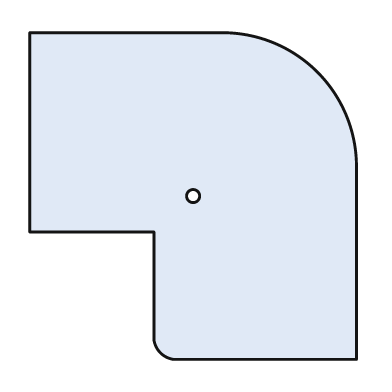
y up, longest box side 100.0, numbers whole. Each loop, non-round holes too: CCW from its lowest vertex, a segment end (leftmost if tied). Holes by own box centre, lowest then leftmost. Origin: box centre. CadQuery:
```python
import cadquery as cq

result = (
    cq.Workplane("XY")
    .moveTo(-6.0, -50.0)
    .lineTo(50.0, -50.0)
    .lineTo(50.0, 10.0)
    .threePointArc((38.0, 38.0), (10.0, 50.0))
    .lineTo(-50.0, 50.0)
    .lineTo(-50.0, -11.0)
    .lineTo(-12.0, -11.0)
    .lineTo(-12.0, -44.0)
    .threePointArc((-10.0, -48.0), (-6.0, -50.0))
    .close()
    .moveTo(0.0, 0.0)
    .circle(2.0)
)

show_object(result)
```